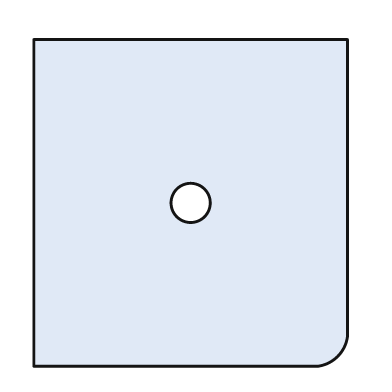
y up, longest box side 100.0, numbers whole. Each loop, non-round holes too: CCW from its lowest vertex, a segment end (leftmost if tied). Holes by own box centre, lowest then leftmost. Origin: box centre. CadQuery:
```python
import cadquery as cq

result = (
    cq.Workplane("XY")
    .moveTo(-48.0, -50.0)
    .lineTo(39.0, -50.0)
    .threePointArc((45.0, -47.0), (48.0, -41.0))
    .lineTo(48.0, 50.0)
    .lineTo(-48.0, 50.0)
    .close()
    .moveTo(0.0, 0.0)
    .circle(6.0)
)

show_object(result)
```